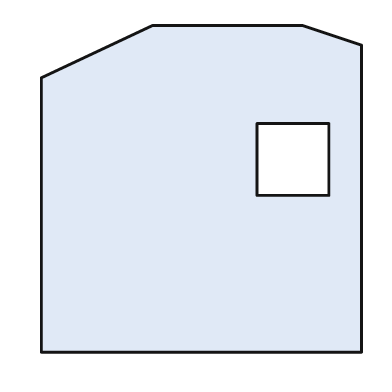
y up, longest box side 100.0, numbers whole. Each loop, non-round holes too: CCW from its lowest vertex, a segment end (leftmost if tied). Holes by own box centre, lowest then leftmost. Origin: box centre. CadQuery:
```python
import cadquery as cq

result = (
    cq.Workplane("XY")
    .moveTo(-49.0, -50.0)
    .lineTo(49.0, -50.0)
    .lineTo(49.0, 44.0)
    .lineTo(31.0, 50.0)
    .lineTo(-15.0, 50.0)
    .lineTo(-49.0, 34.0)
    .close()
    .moveTo(17.0, -2.0)
    .lineTo(39.0, -2.0)
    .lineTo(39.0, 20.0)
    .lineTo(17.0, 20.0)
    .close()
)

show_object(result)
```